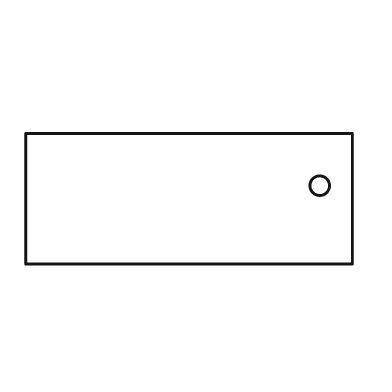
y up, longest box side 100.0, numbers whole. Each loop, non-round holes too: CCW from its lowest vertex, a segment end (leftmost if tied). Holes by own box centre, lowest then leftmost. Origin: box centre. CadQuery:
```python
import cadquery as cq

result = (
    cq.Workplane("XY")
    .moveTo(-50.0, -20.0)
    .lineTo(50.0, -20.0)
    .lineTo(50.0, 20.0)
    .lineTo(-50.0, 20.0)
    .close()
    .moveTo(40.0, 4.0)
    .circle(3.0)
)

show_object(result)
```